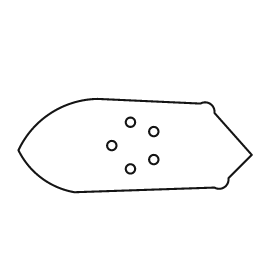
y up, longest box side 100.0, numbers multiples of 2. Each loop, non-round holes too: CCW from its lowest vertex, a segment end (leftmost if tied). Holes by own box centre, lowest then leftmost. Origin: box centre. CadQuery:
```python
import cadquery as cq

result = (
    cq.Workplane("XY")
    .moveTo(-26.0, -20.0)
    .lineTo(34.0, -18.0)
    .threePointArc((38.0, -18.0), (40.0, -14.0))
    .lineTo(50.0, -4.0)
    .lineTo(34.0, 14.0)
    .threePointArc((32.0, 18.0), (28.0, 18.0))
    .lineTo(-16.0, 20.0)
    .threePointArc((-36.0, 14.0), (-50.0, -2.0))
    .threePointArc((-40.0, -14.0), (-26.0, -20.0))
    .close()
    .moveTo(-2.0, -10.0)
    .circle(2.0)
    .moveTo(8.0, -6.0)
    .circle(2.0)
    .moveTo(-10.0, 0.0)
    .circle(2.0)
    .moveTo(8.0, 6.0)
    .circle(2.0)
    .moveTo(-2.0, 10.0)
    .circle(2.0)
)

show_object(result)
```